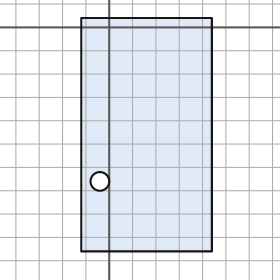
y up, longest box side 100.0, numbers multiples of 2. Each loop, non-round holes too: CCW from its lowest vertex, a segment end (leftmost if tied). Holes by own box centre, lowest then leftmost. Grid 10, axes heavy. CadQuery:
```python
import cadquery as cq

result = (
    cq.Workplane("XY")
    .moveTo(-12.0, -96.0)
    .lineTo(44.0, -96.0)
    .lineTo(44.0, 4.0)
    .lineTo(-12.0, 4.0)
    .close()
    .moveTo(-4.0, -66.0)
    .circle(4.0)
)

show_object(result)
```